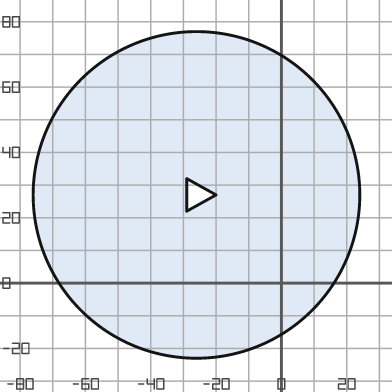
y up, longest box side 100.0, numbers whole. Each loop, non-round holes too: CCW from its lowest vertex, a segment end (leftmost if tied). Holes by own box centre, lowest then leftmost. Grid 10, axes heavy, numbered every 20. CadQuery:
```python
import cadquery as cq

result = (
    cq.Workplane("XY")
    .moveTo(-26.0, 27.0)
    .circle(50.0)
    .moveTo(-29.0, 22.0)
    .lineTo(-20.0, 27.0)
    .lineTo(-29.0, 32.0)
    .close()
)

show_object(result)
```